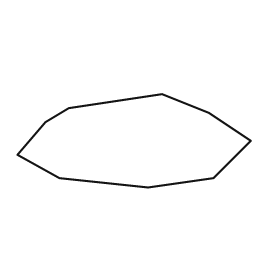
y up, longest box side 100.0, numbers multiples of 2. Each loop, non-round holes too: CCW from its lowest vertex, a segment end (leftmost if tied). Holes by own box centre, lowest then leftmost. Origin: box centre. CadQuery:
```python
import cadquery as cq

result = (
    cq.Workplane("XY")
    .moveTo(6.0, -20.0)
    .lineTo(34.0, -16.0)
    .lineTo(50.0, 0.0)
    .lineTo(32.0, 12.0)
    .lineTo(12.0, 20.0)
    .lineTo(-28.0, 14.0)
    .lineTo(-38.0, 8.0)
    .lineTo(-50.0, -6.0)
    .lineTo(-32.0, -16.0)
    .close()
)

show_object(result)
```